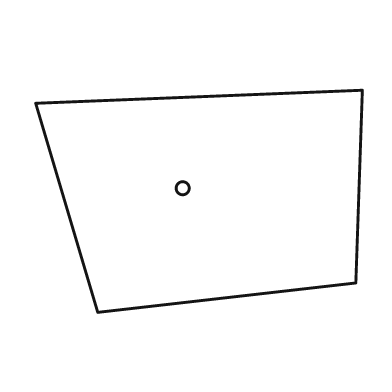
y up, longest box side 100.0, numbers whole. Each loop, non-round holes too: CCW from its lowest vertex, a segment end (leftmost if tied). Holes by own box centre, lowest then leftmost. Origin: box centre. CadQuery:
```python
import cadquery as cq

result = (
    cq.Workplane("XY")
    .moveTo(-31.0, -34.0)
    .lineTo(48.0, -25.0)
    .lineTo(50.0, 34.0)
    .lineTo(-50.0, 30.0)
    .close()
    .moveTo(-5.0, 4.0)
    .circle(2.0)
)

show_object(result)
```